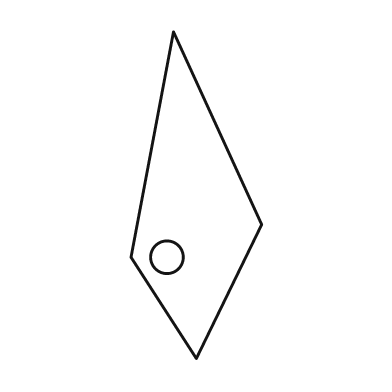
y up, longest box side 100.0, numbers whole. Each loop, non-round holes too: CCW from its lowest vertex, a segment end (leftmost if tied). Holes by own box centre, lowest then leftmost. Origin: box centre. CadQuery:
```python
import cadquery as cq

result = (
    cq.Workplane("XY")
    .moveTo(0.0, -50.0)
    .lineTo(20.0, -9.0)
    .lineTo(-7.0, 50.0)
    .lineTo(-20.0, -19.0)
    .close()
    .moveTo(-9.0, -19.0)
    .circle(5.0)
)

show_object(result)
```